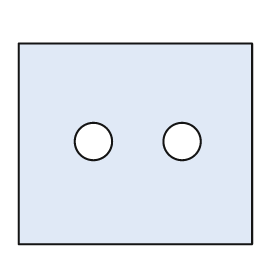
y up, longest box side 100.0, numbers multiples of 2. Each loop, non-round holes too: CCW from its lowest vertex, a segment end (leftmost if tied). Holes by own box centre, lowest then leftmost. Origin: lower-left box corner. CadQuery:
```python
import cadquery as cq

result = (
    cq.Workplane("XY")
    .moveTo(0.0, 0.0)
    .lineTo(100.0, 0.0)
    .lineTo(100.0, 86.0)
    .lineTo(0.0, 86.0)
    .close()
    .moveTo(32.0, 44.0)
    .circle(8.0)
    .moveTo(70.0, 44.0)
    .circle(8.0)
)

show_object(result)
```